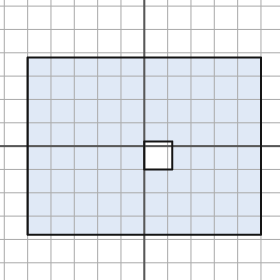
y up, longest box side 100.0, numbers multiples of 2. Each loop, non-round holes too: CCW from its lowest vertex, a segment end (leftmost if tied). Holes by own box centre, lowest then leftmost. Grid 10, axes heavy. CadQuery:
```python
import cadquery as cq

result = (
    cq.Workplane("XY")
    .moveTo(-50.0, -38.0)
    .lineTo(50.0, -38.0)
    .lineTo(50.0, 38.0)
    .lineTo(-50.0, 38.0)
    .close()
    .moveTo(0.0, -10.0)
    .lineTo(12.0, -10.0)
    .lineTo(12.0, 2.0)
    .lineTo(0.0, 2.0)
    .close()
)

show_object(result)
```